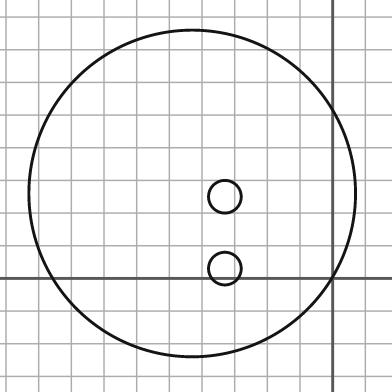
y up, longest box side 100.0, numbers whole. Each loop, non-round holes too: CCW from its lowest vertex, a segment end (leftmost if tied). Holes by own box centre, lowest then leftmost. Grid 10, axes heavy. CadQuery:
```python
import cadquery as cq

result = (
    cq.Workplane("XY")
    .moveTo(-43.0, 26.0)
    .circle(50.0)
    .moveTo(-33.0, 3.0)
    .circle(5.0)
    .moveTo(-33.0, 25.0)
    .circle(5.0)
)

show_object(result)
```